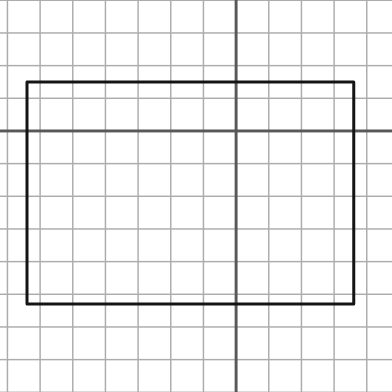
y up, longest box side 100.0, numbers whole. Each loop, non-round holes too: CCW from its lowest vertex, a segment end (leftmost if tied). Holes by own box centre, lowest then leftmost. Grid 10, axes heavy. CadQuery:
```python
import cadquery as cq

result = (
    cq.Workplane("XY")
    .moveTo(-64.0, -53.0)
    .lineTo(36.0, -53.0)
    .lineTo(36.0, 15.0)
    .lineTo(-64.0, 15.0)
    .close()
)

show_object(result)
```